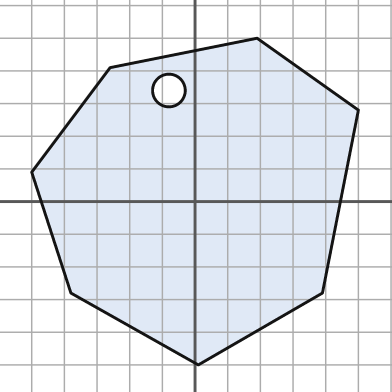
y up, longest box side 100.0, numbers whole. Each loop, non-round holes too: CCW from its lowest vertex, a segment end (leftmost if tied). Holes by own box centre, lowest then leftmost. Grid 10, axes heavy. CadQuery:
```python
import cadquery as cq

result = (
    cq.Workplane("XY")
    .moveTo(1.0, -50.0)
    .lineTo(39.0, -28.0)
    .lineTo(50.0, 28.0)
    .lineTo(19.0, 50.0)
    .lineTo(-26.0, 41.0)
    .lineTo(-50.0, 9.0)
    .lineTo(-38.0, -28.0)
    .close()
    .moveTo(-8.0, 34.0)
    .circle(5.0)
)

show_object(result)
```